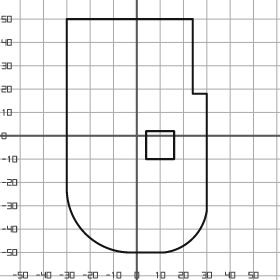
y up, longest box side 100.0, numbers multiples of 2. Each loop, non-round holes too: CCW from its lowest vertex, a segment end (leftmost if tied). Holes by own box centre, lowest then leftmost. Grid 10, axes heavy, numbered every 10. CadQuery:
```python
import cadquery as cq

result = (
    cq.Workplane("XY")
    .moveTo(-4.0, -50.0)
    .lineTo(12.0, -50.0)
    .threePointArc((24.0, -44.0), (30.0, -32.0))
    .lineTo(30.0, 18.0)
    .lineTo(24.0, 18.0)
    .lineTo(24.0, 50.0)
    .lineTo(-30.0, 50.0)
    .lineTo(-30.0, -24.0)
    .threePointArc((-22.0, -42.0), (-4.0, -50.0))
    .close()
    .moveTo(4.0, -10.0)
    .lineTo(16.0, -10.0)
    .lineTo(16.0, 2.0)
    .lineTo(4.0, 2.0)
    .close()
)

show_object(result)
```